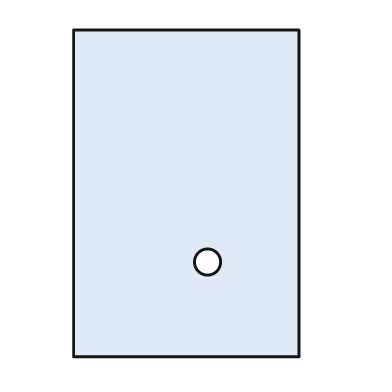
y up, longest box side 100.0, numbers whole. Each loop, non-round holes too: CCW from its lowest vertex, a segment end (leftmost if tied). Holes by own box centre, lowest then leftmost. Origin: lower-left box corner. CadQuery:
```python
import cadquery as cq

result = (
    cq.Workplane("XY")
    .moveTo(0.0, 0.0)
    .lineTo(69.0, 0.0)
    .lineTo(69.0, 100.0)
    .lineTo(0.0, 100.0)
    .close()
    .moveTo(41.0, 29.0)
    .circle(4.0)
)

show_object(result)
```